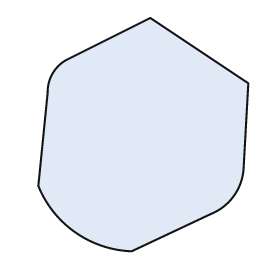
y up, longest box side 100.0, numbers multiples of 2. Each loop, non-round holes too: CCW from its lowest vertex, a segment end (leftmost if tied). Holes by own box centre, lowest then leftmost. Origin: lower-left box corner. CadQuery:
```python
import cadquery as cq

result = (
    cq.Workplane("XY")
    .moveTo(40.0, 0.0)
    .lineTo(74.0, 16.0)
    .threePointArc((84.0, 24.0), (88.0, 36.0))
    .lineTo(90.0, 72.0)
    .lineTo(48.0, 100.0)
    .lineTo(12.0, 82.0)
    .threePointArc((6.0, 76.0), (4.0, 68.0))
    .lineTo(0.0, 28.0)
    .threePointArc((16.0, 8.0), (40.0, 0.0))
    .close()
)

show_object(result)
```